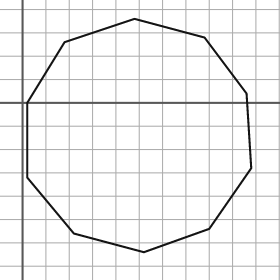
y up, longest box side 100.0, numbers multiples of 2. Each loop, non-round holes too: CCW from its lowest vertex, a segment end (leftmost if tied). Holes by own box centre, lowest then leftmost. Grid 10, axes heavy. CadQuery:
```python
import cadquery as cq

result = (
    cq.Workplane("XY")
    .moveTo(52.0, -64.0)
    .lineTo(80.0, -54.0)
    .lineTo(98.0, -28.0)
    .lineTo(96.0, 4.0)
    .lineTo(78.0, 28.0)
    .lineTo(48.0, 36.0)
    .lineTo(18.0, 26.0)
    .lineTo(2.0, 0.0)
    .lineTo(2.0, -32.0)
    .lineTo(22.0, -56.0)
    .close()
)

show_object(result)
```